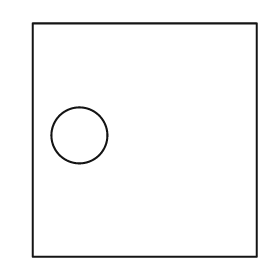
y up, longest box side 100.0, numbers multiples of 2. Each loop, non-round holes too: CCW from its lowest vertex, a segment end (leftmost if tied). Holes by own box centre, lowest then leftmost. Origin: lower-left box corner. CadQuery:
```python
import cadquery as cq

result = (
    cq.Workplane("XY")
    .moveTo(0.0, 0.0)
    .lineTo(96.0, 0.0)
    .lineTo(96.0, 100.0)
    .lineTo(0.0, 100.0)
    .close()
    .moveTo(20.0, 52.0)
    .circle(12.0)
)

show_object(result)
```